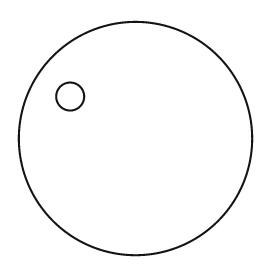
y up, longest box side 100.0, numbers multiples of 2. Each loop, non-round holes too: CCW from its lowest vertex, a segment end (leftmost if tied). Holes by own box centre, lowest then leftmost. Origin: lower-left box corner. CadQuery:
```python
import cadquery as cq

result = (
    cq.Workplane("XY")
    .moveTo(50.0, 50.0)
    .circle(50.0)
    .moveTo(22.0, 68.0)
    .circle(6.0)
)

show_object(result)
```